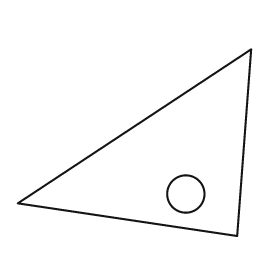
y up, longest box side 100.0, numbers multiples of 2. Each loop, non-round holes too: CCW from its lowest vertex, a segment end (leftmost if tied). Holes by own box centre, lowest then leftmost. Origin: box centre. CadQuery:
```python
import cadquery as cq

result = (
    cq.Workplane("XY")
    .moveTo(44.0, -40.0)
    .lineTo(50.0, 40.0)
    .lineTo(-50.0, -26.0)
    .close()
    .moveTo(22.0, -22.0)
    .circle(8.0)
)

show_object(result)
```